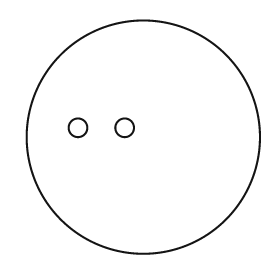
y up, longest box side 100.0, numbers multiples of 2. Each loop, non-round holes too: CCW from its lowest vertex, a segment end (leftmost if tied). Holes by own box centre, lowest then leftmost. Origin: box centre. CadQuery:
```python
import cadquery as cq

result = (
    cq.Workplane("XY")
    .moveTo(0.0, 0.0)
    .circle(50.0)
    .moveTo(-28.0, 4.0)
    .circle(4.0)
    .moveTo(-8.0, 4.0)
    .circle(4.0)
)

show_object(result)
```